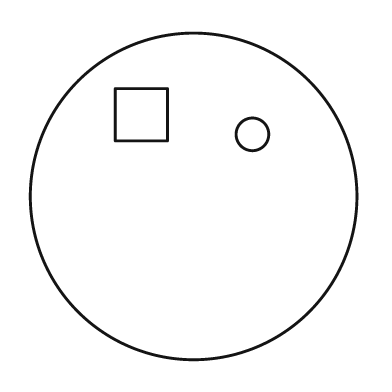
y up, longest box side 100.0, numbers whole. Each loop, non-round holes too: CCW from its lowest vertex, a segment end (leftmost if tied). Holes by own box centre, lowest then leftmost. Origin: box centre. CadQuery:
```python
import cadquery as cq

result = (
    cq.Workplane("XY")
    .moveTo(0.0, 0.0)
    .circle(50.0)
    .moveTo(18.0, 19.0)
    .circle(5.0)
    .moveTo(-24.0, 17.0)
    .lineTo(-8.0, 17.0)
    .lineTo(-8.0, 33.0)
    .lineTo(-24.0, 33.0)
    .close()
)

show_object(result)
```